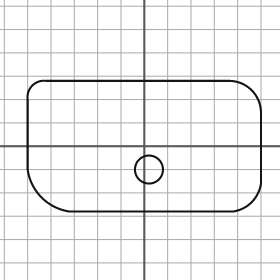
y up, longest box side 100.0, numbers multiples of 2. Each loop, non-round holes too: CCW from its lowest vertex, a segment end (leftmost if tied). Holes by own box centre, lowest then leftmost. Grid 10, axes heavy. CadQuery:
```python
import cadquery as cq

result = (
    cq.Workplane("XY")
    .moveTo(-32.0, -28.0)
    .lineTo(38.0, -28.0)
    .threePointArc((46.0, -24.0), (50.0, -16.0))
    .lineTo(50.0, 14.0)
    .threePointArc((46.0, 24.0), (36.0, 28.0))
    .lineTo(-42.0, 28.0)
    .threePointArc((-48.0, 26.0), (-50.0, 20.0))
    .lineTo(-50.0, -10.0)
    .threePointArc((-44.0, -22.0), (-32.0, -28.0))
    .close()
    .moveTo(2.0, -10.0)
    .circle(6.0)
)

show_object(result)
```